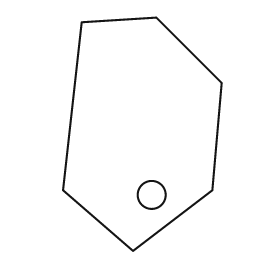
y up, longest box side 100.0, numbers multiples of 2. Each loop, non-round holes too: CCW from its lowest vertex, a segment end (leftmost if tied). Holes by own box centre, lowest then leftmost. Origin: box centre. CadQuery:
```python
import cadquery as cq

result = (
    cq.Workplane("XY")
    .moveTo(-4.0, -50.0)
    .lineTo(30.0, -24.0)
    .lineTo(34.0, 22.0)
    .lineTo(6.0, 50.0)
    .lineTo(-26.0, 48.0)
    .lineTo(-34.0, -24.0)
    .close()
    .moveTo(4.0, -26.0)
    .circle(6.0)
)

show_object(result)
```